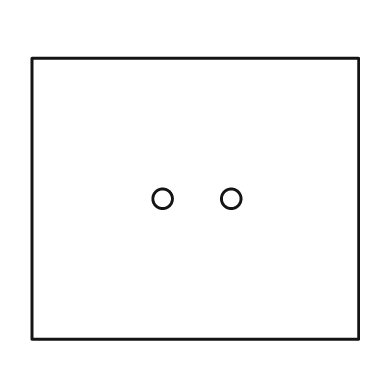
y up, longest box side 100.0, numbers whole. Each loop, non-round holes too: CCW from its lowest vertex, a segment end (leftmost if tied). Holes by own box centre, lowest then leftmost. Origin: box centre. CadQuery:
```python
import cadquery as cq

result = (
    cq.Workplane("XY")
    .moveTo(-50.0, -43.0)
    .lineTo(50.0, -43.0)
    .lineTo(50.0, 43.0)
    .lineTo(-50.0, 43.0)
    .close()
    .moveTo(-10.0, 0.0)
    .circle(3.0)
    .moveTo(11.0, 0.0)
    .circle(3.0)
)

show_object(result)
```